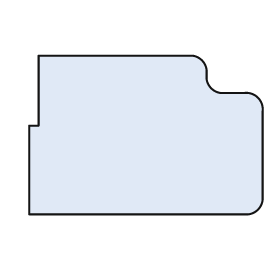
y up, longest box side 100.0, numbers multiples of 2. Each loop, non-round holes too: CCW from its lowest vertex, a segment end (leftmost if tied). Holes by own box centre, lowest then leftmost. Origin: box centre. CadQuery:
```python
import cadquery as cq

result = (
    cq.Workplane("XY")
    .moveTo(-50.0, -34.0)
    .lineTo(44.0, -34.0)
    .threePointArc((48.0, -32.0), (50.0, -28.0))
    .lineTo(50.0, 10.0)
    .threePointArc((48.0, 16.0), (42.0, 18.0))
    .lineTo(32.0, 18.0)
    .threePointArc((28.0, 20.0), (26.0, 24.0))
    .lineTo(26.0, 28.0)
    .threePointArc((24.0, 32.0), (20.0, 34.0))
    .lineTo(-46.0, 34.0)
    .lineTo(-46.0, 4.0)
    .lineTo(-50.0, 4.0)
    .close()
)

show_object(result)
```